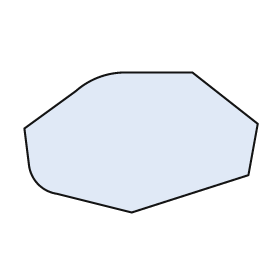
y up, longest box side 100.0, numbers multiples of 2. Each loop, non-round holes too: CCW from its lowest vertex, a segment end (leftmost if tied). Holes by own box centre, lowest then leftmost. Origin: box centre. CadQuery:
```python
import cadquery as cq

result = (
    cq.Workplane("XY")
    .moveTo(-4.0, -30.0)
    .lineTo(46.0, -14.0)
    .lineTo(50.0, 8.0)
    .lineTo(22.0, 30.0)
    .lineTo(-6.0, 30.0)
    .threePointArc((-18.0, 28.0), (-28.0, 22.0))
    .lineTo(-50.0, 6.0)
    .lineTo(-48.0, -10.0)
    .threePointArc((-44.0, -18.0), (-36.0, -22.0))
    .close()
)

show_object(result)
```